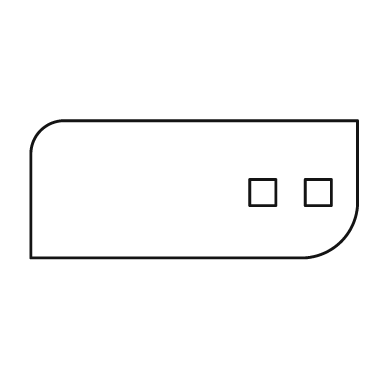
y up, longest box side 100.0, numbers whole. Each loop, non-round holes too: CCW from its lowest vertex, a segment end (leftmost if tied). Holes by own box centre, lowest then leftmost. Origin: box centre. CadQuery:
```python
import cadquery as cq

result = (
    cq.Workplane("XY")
    .moveTo(-50.0, -21.0)
    .lineTo(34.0, -21.0)
    .threePointArc((45.0, -16.0), (50.0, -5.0))
    .lineTo(50.0, 21.0)
    .lineTo(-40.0, 21.0)
    .threePointArc((-47.0, 18.0), (-50.0, 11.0))
    .close()
    .moveTo(17.0, -5.0)
    .lineTo(25.0, -5.0)
    .lineTo(25.0, 3.0)
    .lineTo(17.0, 3.0)
    .close()
    .moveTo(34.0, -5.0)
    .lineTo(42.0, -5.0)
    .lineTo(42.0, 3.0)
    .lineTo(34.0, 3.0)
    .close()
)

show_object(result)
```